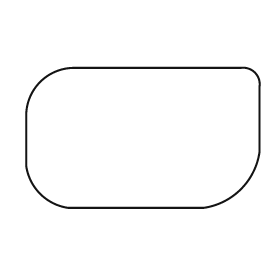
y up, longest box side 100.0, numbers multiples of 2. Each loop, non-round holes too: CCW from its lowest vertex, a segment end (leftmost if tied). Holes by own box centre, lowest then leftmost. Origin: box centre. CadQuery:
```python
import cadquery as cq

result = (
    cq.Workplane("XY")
    .moveTo(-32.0, -30.0)
    .lineTo(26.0, -30.0)
    .threePointArc((42.0, -22.0), (50.0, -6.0))
    .lineTo(50.0, 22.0)
    .threePointArc((48.0, 28.0), (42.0, 30.0))
    .lineTo(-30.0, 30.0)
    .threePointArc((-44.0, 24.0), (-50.0, 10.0))
    .lineTo(-50.0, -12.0)
    .threePointArc((-44.0, -24.0), (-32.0, -30.0))
    .close()
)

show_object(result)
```